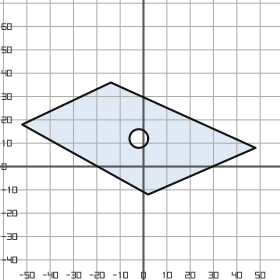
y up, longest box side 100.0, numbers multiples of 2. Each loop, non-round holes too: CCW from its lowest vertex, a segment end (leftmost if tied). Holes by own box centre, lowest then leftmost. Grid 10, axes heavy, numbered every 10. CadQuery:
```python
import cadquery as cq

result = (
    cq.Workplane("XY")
    .moveTo(2.0, -12.0)
    .lineTo(48.0, 8.0)
    .lineTo(-14.0, 36.0)
    .lineTo(-52.0, 18.0)
    .close()
    .moveTo(-2.0, 12.0)
    .circle(4.0)
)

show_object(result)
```